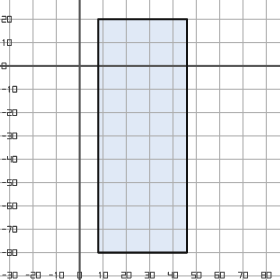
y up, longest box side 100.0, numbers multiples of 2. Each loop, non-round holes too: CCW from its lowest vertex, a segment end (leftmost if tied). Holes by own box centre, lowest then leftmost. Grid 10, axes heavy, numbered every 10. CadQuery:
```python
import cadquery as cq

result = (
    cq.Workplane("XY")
    .moveTo(8.0, -80.0)
    .lineTo(46.0, -80.0)
    .lineTo(46.0, 20.0)
    .lineTo(8.0, 20.0)
    .close()
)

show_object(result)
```